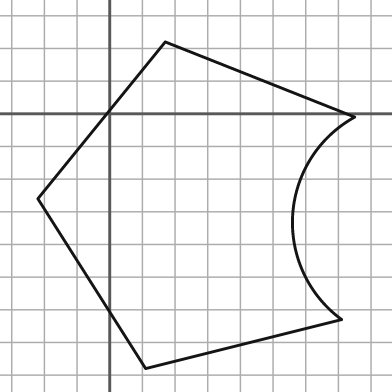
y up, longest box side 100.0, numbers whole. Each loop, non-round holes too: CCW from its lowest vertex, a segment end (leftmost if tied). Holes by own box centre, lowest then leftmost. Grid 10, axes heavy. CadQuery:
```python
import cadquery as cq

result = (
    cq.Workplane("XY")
    .moveTo(11.0, -78.0)
    .lineTo(71.0, -63.0)
    .threePointArc((56.0, -31.0), (75.0, -1.0))
    .lineTo(17.0, 22.0)
    .lineTo(-22.0, -26.0)
    .close()
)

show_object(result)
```